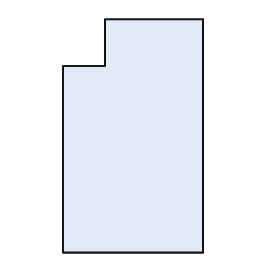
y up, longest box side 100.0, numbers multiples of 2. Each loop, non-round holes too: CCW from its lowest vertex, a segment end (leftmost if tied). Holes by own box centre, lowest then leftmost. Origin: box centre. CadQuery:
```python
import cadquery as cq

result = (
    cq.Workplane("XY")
    .moveTo(-30.0, -50.0)
    .lineTo(30.0, -50.0)
    .lineTo(30.0, 50.0)
    .lineTo(-12.0, 50.0)
    .lineTo(-12.0, 30.0)
    .lineTo(-30.0, 30.0)
    .close()
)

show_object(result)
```